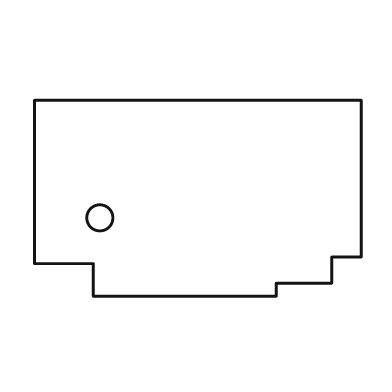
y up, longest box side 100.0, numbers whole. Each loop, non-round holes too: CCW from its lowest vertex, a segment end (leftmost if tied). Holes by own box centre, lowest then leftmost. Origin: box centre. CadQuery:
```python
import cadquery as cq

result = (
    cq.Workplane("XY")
    .moveTo(-32.0, -30.0)
    .lineTo(24.0, -30.0)
    .lineTo(24.0, -26.0)
    .lineTo(41.0, -26.0)
    .lineTo(41.0, -18.0)
    .lineTo(50.0, -18.0)
    .lineTo(50.0, 30.0)
    .lineTo(-50.0, 30.0)
    .lineTo(-50.0, -20.0)
    .lineTo(-32.0, -20.0)
    .close()
    .moveTo(-30.0, -6.0)
    .circle(4.0)
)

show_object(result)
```